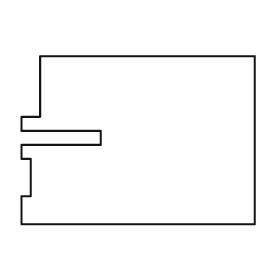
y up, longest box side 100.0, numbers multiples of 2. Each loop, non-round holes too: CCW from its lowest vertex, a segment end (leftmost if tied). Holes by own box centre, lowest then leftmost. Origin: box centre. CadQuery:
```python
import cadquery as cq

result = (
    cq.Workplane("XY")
    .moveTo(-50.0, -36.0)
    .lineTo(50.0, -36.0)
    .lineTo(50.0, 36.0)
    .lineTo(-42.0, 36.0)
    .lineTo(-42.0, 10.0)
    .lineTo(-50.0, 10.0)
    .lineTo(-50.0, 4.0)
    .lineTo(-16.0, 4.0)
    .lineTo(-16.0, -2.0)
    .lineTo(-50.0, -2.0)
    .lineTo(-50.0, -8.0)
    .lineTo(-46.0, -8.0)
    .lineTo(-46.0, -24.0)
    .lineTo(-50.0, -24.0)
    .close()
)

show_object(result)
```